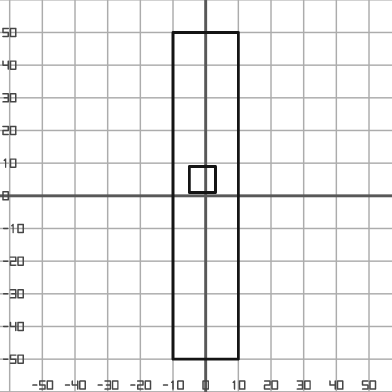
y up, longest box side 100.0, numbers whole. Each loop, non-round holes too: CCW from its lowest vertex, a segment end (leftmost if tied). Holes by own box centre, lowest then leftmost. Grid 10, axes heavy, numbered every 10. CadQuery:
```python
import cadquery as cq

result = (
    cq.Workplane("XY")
    .moveTo(-10.0, -50.0)
    .lineTo(10.0, -50.0)
    .lineTo(10.0, 50.0)
    .lineTo(-10.0, 50.0)
    .close()
    .moveTo(-5.0, 1.0)
    .lineTo(3.0, 1.0)
    .lineTo(3.0, 9.0)
    .lineTo(-5.0, 9.0)
    .close()
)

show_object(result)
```